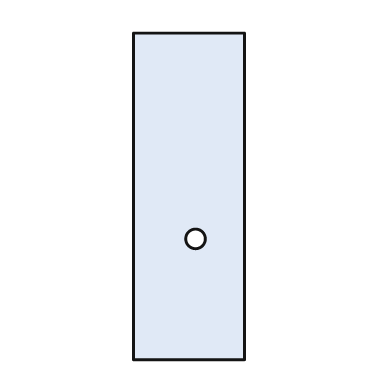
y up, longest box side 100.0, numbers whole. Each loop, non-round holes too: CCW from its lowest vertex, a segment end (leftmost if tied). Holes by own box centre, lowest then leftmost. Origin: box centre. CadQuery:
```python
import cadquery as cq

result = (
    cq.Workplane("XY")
    .moveTo(-17.0, -50.0)
    .lineTo(17.0, -50.0)
    .lineTo(17.0, 50.0)
    .lineTo(-17.0, 50.0)
    .close()
    .moveTo(2.0, -13.0)
    .circle(3.0)
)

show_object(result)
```